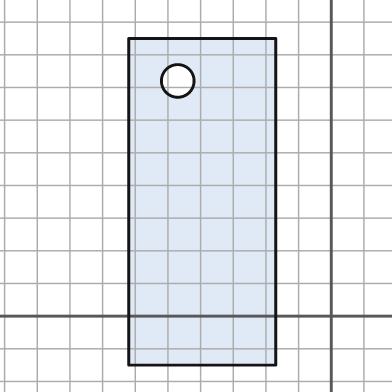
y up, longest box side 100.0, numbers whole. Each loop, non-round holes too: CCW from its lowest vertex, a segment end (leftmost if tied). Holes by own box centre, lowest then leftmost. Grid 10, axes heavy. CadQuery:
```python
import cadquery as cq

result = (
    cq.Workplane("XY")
    .moveTo(-62.0, -15.0)
    .lineTo(-17.0, -15.0)
    .lineTo(-17.0, 85.0)
    .lineTo(-62.0, 85.0)
    .close()
    .moveTo(-47.0, 72.0)
    .circle(5.0)
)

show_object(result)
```